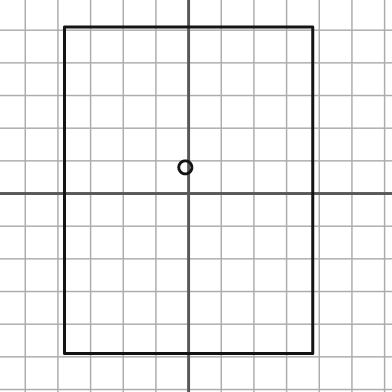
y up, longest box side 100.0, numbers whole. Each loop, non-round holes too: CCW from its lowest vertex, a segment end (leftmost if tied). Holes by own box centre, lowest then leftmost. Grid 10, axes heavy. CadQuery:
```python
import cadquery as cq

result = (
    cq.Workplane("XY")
    .moveTo(-38.0, -49.0)
    .lineTo(38.0, -49.0)
    .lineTo(38.0, 51.0)
    .lineTo(-38.0, 51.0)
    .close()
    .moveTo(-1.0, 8.0)
    .circle(2.0)
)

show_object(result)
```